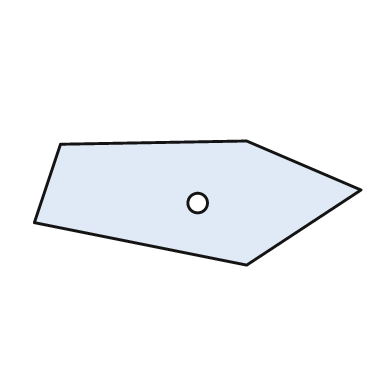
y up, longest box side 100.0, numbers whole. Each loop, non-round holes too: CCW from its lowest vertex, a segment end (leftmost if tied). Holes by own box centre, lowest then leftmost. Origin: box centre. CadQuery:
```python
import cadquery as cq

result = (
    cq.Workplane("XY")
    .moveTo(15.0, -19.0)
    .lineTo(50.0, 4.0)
    .lineTo(15.0, 19.0)
    .lineTo(-42.0, 18.0)
    .lineTo(-50.0, -6.0)
    .close()
    .moveTo(0.0, 0.0)
    .circle(3.0)
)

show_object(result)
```